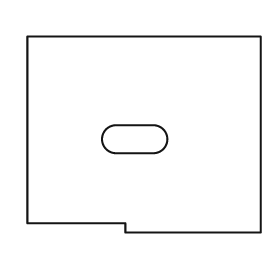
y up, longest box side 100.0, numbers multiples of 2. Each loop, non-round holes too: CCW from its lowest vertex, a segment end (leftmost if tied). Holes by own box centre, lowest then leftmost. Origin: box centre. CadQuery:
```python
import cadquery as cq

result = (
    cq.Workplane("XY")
    .moveTo(-8.0, -42.0)
    .lineTo(50.0, -42.0)
    .lineTo(50.0, 42.0)
    .lineTo(-50.0, 42.0)
    .lineTo(-50.0, -38.0)
    .lineTo(-8.0, -38.0)
    .close()
    .moveTo(-12.0, -8.0)
    .lineTo(4.0, -8.0)
    .threePointArc((10.0, -2.0), (4.0, 4.0))
    .lineTo(-12.0, 4.0)
    .threePointArc((-18.0, -2.0), (-12.0, -8.0))
    .close()
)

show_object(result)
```